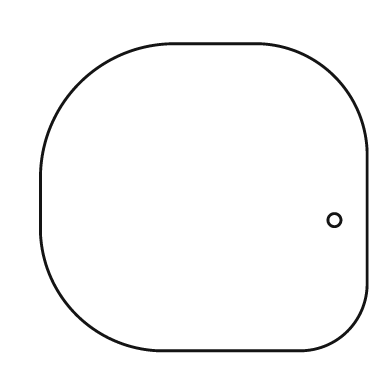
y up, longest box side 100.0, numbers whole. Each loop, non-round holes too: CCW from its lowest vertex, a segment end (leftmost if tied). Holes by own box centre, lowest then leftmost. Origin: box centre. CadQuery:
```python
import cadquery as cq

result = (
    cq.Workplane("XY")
    .moveTo(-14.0, -47.0)
    .lineTo(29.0, -47.0)
    .threePointArc((44.0, -41.0), (50.0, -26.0))
    .lineTo(50.0, 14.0)
    .threePointArc((40.0, 37.0), (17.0, 47.0))
    .lineTo(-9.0, 47.0)
    .threePointArc((-38.0, 35.0), (-50.0, 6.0))
    .lineTo(-50.0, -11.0)
    .threePointArc((-39.0, -36.0), (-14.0, -47.0))
    .close()
    .moveTo(40.0, -7.0)
    .circle(2.0)
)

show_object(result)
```